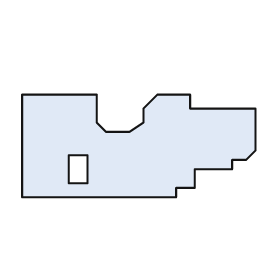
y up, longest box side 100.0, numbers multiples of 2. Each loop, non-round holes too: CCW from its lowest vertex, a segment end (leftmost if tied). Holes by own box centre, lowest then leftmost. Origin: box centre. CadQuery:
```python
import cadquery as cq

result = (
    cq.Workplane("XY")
    .moveTo(-50.0, -22.0)
    .lineTo(16.0, -22.0)
    .lineTo(16.0, -18.0)
    .lineTo(24.0, -18.0)
    .lineTo(24.0, -10.0)
    .lineTo(40.0, -10.0)
    .lineTo(40.0, -6.0)
    .lineTo(46.0, -6.0)
    .lineTo(50.0, -2.0)
    .lineTo(50.0, 16.0)
    .lineTo(22.0, 16.0)
    .lineTo(22.0, 22.0)
    .lineTo(8.0, 22.0)
    .lineTo(2.0, 16.0)
    .lineTo(2.0, 10.0)
    .lineTo(-4.0, 6.0)
    .lineTo(-14.0, 6.0)
    .lineTo(-18.0, 10.0)
    .lineTo(-18.0, 22.0)
    .lineTo(-50.0, 22.0)
    .close()
    .moveTo(-30.0, -16.0)
    .lineTo(-22.0, -16.0)
    .lineTo(-22.0, -4.0)
    .lineTo(-30.0, -4.0)
    .close()
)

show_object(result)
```